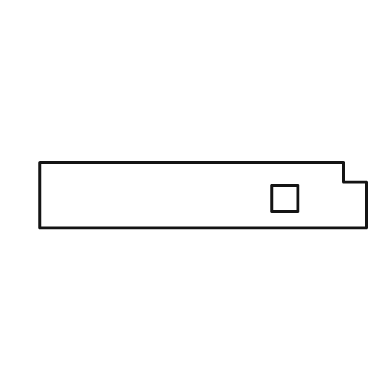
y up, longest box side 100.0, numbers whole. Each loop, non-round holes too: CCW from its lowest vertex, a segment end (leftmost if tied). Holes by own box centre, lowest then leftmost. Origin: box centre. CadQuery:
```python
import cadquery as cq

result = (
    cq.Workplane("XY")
    .moveTo(-50.0, -10.0)
    .lineTo(50.0, -10.0)
    .lineTo(50.0, 4.0)
    .lineTo(43.0, 4.0)
    .lineTo(43.0, 10.0)
    .lineTo(-50.0, 10.0)
    .close()
    .moveTo(21.0, -5.0)
    .lineTo(29.0, -5.0)
    .lineTo(29.0, 3.0)
    .lineTo(21.0, 3.0)
    .close()
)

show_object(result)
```